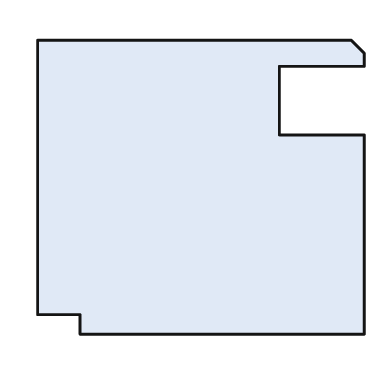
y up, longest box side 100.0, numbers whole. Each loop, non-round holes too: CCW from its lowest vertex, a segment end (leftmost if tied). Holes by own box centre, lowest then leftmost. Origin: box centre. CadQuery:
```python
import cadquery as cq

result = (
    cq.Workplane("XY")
    .moveTo(-37.0, -45.0)
    .lineTo(50.0, -45.0)
    .lineTo(50.0, 16.0)
    .lineTo(24.0, 16.0)
    .lineTo(24.0, 37.0)
    .lineTo(50.0, 37.0)
    .lineTo(50.0, 41.0)
    .lineTo(46.0, 45.0)
    .lineTo(-50.0, 45.0)
    .lineTo(-50.0, -39.0)
    .lineTo(-37.0, -39.0)
    .close()
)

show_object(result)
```